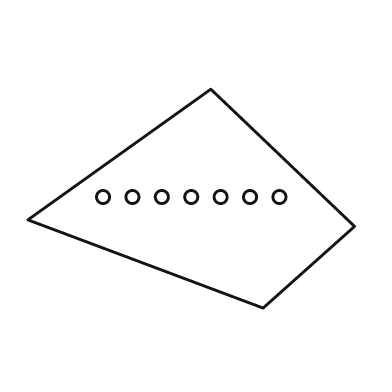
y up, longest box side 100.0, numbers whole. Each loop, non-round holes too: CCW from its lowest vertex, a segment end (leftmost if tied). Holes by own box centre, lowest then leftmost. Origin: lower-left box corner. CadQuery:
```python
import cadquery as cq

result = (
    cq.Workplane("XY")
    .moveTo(72.0, 0.0)
    .lineTo(100.0, 25.0)
    .lineTo(56.0, 67.0)
    .lineTo(0.0, 27.0)
    .close()
    .moveTo(23.0, 34.0)
    .circle(2.0)
    .moveTo(32.0, 34.0)
    .circle(2.0)
    .moveTo(41.0, 34.0)
    .circle(2.0)
    .moveTo(50.0, 34.0)
    .circle(2.0)
    .moveTo(59.0, 34.0)
    .circle(2.0)
    .moveTo(68.0, 34.0)
    .circle(2.0)
    .moveTo(77.0, 34.0)
    .circle(2.0)
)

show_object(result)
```